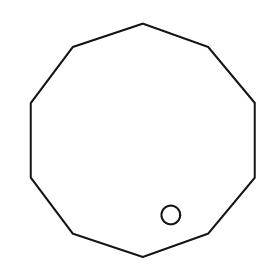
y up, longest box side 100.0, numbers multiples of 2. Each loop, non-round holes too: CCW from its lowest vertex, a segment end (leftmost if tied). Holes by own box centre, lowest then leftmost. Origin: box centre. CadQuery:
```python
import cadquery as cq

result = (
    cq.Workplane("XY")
    .moveTo(0.0, -50.0)
    .lineTo(28.0, -40.0)
    .lineTo(48.0, -16.0)
    .lineTo(48.0, 16.0)
    .lineTo(28.0, 40.0)
    .lineTo(0.0, 50.0)
    .lineTo(-30.0, 40.0)
    .lineTo(-48.0, 16.0)
    .lineTo(-48.0, -16.0)
    .lineTo(-30.0, -40.0)
    .close()
    .moveTo(12.0, -32.0)
    .circle(4.0)
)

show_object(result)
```